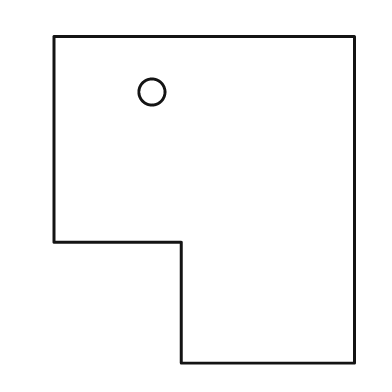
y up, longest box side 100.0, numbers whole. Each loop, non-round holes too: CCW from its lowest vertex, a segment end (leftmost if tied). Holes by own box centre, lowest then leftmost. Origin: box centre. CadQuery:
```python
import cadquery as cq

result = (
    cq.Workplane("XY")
    .moveTo(-7.0, -50.0)
    .lineTo(46.0, -50.0)
    .lineTo(46.0, 50.0)
    .lineTo(-46.0, 50.0)
    .lineTo(-46.0, -13.0)
    .lineTo(-7.0, -13.0)
    .close()
    .moveTo(-16.0, 33.0)
    .circle(4.0)
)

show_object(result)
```